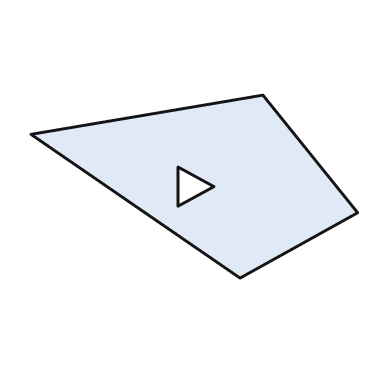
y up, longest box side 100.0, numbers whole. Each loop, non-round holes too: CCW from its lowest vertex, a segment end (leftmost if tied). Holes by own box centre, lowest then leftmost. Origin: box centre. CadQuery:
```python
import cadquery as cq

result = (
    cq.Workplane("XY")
    .moveTo(14.0, -28.0)
    .lineTo(50.0, -8.0)
    .lineTo(21.0, 28.0)
    .lineTo(-50.0, 16.0)
    .close()
    .moveTo(-5.0, -6.0)
    .lineTo(6.0, 0.0)
    .lineTo(-5.0, 6.0)
    .close()
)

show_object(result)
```